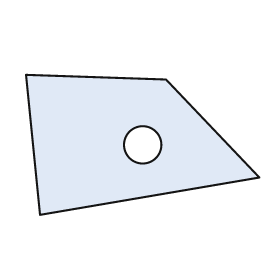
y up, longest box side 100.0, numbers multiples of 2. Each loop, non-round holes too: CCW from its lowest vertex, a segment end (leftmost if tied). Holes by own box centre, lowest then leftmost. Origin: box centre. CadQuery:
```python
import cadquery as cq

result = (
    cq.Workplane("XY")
    .moveTo(-44.0, -30.0)
    .lineTo(50.0, -14.0)
    .lineTo(10.0, 28.0)
    .lineTo(-50.0, 30.0)
    .close()
    .moveTo(0.0, 0.0)
    .circle(8.0)
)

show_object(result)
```